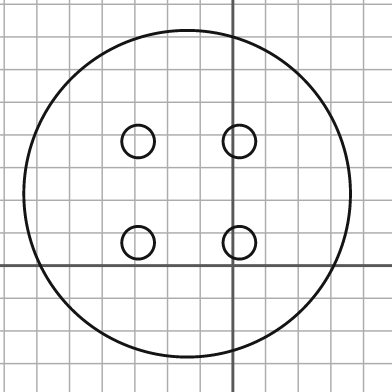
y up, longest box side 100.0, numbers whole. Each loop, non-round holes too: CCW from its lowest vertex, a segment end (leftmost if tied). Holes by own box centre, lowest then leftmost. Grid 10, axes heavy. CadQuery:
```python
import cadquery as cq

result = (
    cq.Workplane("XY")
    .moveTo(-14.0, 22.0)
    .circle(50.0)
    .moveTo(-29.0, 7.0)
    .circle(5.0)
    .moveTo(2.0, 7.0)
    .circle(5.0)
    .moveTo(-29.0, 38.0)
    .circle(5.0)
    .moveTo(2.0, 38.0)
    .circle(5.0)
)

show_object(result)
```